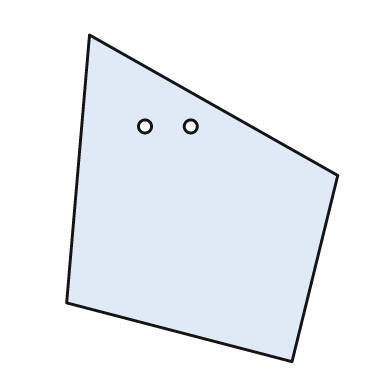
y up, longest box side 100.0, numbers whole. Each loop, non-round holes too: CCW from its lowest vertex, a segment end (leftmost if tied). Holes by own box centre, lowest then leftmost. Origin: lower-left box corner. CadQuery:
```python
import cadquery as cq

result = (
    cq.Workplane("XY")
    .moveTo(69.0, 0.0)
    .lineTo(83.0, 57.0)
    .lineTo(7.0, 100.0)
    .lineTo(0.0, 18.0)
    .close()
    .moveTo(24.0, 72.0)
    .circle(2.0)
    .moveTo(38.0, 72.0)
    .circle(2.0)
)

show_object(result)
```